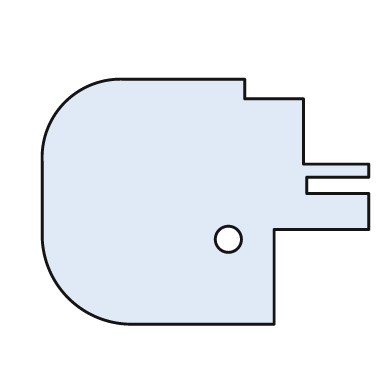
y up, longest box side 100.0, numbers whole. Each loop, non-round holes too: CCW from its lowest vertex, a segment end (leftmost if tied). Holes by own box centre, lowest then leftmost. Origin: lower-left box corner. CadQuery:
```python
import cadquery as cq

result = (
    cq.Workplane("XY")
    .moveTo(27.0, 0.0)
    .lineTo(71.0, 0.0)
    .lineTo(71.0, 29.0)
    .lineTo(100.0, 29.0)
    .lineTo(100.0, 40.0)
    .lineTo(81.0, 40.0)
    .lineTo(81.0, 45.0)
    .lineTo(100.0, 45.0)
    .lineTo(100.0, 49.0)
    .lineTo(80.0, 49.0)
    .lineTo(80.0, 69.0)
    .lineTo(62.0, 69.0)
    .lineTo(62.0, 75.0)
    .lineTo(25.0, 75.0)
    .threePointArc((7.0, 68.0), (0.0, 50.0))
    .lineTo(0.0, 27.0)
    .threePointArc((8.0, 8.0), (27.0, 0.0))
    .close()
    .moveTo(57.0, 26.0)
    .circle(4.0)
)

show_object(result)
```